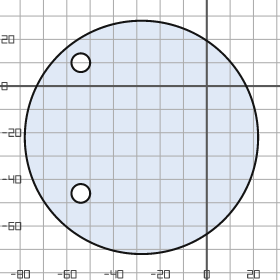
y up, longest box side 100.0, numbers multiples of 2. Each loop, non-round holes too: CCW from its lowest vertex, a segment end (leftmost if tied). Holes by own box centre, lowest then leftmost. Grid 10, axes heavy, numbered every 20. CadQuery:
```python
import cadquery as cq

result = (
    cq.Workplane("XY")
    .moveTo(-28.0, -22.0)
    .circle(50.0)
    .moveTo(-54.0, -46.0)
    .circle(4.0)
    .moveTo(-54.0, 10.0)
    .circle(4.0)
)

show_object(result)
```